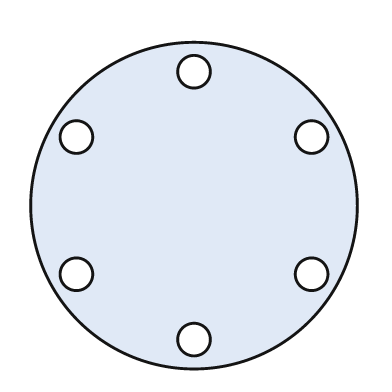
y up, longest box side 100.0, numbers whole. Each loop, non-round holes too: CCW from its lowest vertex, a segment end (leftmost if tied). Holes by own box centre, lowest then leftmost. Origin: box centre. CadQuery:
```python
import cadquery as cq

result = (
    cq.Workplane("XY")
    .moveTo(0.0, 0.0)
    .circle(50.0)
    .moveTo(0.0, -41.0)
    .circle(5.0)
    .moveTo(-36.0, -21.0)
    .circle(5.0)
    .moveTo(36.0, -21.0)
    .circle(5.0)
    .moveTo(-36.0, 21.0)
    .circle(5.0)
    .moveTo(36.0, 21.0)
    .circle(5.0)
    .moveTo(0.0, 41.0)
    .circle(5.0)
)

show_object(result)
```